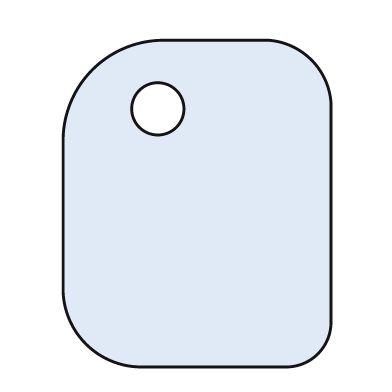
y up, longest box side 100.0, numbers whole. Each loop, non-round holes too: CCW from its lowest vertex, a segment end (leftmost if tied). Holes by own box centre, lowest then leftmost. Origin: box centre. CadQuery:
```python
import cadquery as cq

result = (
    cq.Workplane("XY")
    .moveTo(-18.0, -50.0)
    .lineTo(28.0, -50.0)
    .threePointArc((37.0, -46.0), (41.0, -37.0))
    .lineTo(41.0, 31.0)
    .threePointArc((35.0, 44.0), (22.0, 50.0))
    .lineTo(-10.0, 50.0)
    .threePointArc((-32.0, 41.0), (-41.0, 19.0))
    .lineTo(-41.0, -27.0)
    .threePointArc((-34.0, -43.0), (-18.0, -50.0))
    .close()
    .moveTo(-12.0, 29.0)
    .circle(8.0)
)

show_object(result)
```